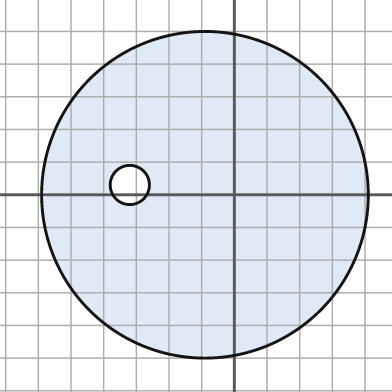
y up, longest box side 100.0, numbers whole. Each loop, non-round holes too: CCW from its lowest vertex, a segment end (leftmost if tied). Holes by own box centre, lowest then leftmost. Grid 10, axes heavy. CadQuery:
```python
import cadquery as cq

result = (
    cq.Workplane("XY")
    .moveTo(-9.0, 0.0)
    .circle(50.0)
    .moveTo(-32.0, 3.0)
    .circle(6.0)
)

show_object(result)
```